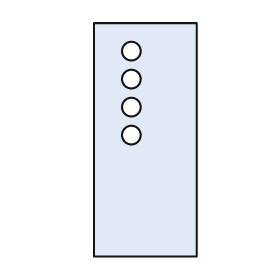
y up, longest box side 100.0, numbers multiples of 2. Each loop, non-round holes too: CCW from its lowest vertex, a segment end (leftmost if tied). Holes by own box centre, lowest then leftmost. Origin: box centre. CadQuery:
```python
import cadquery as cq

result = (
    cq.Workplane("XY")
    .moveTo(-22.0, -50.0)
    .lineTo(22.0, -50.0)
    .lineTo(22.0, 50.0)
    .lineTo(-22.0, 50.0)
    .close()
    .moveTo(-6.0, 2.0)
    .circle(4.0)
    .moveTo(-6.0, 14.0)
    .circle(4.0)
    .moveTo(-6.0, 26.0)
    .circle(4.0)
    .moveTo(-6.0, 38.0)
    .circle(4.0)
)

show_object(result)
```